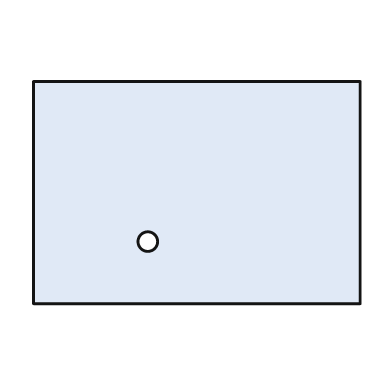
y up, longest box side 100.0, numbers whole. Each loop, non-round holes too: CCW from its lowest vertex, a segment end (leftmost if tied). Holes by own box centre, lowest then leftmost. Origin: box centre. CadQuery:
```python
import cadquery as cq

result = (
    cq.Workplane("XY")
    .moveTo(-50.0, -34.0)
    .lineTo(50.0, -34.0)
    .lineTo(50.0, 34.0)
    .lineTo(-50.0, 34.0)
    .close()
    .moveTo(-15.0, -15.0)
    .circle(3.0)
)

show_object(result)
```